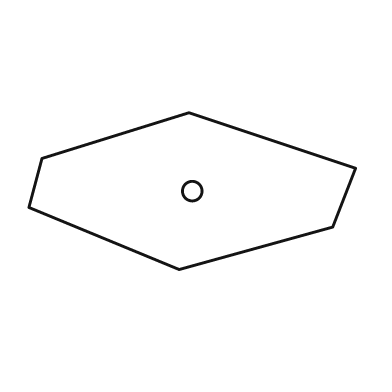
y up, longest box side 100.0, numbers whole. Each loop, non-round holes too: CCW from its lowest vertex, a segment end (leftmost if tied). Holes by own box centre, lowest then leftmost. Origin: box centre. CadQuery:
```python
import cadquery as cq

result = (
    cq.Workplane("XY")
    .moveTo(-4.0, -24.0)
    .lineTo(43.0, -11.0)
    .lineTo(50.0, 7.0)
    .lineTo(-1.0, 24.0)
    .lineTo(-46.0, 10.0)
    .lineTo(-50.0, -5.0)
    .close()
    .moveTo(0.0, 0.0)
    .circle(3.0)
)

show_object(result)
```